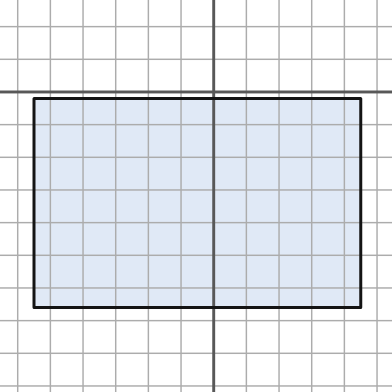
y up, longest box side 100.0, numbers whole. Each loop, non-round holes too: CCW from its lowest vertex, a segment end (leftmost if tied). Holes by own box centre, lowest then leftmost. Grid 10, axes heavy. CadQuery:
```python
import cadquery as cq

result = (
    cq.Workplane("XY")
    .moveTo(-55.0, -66.0)
    .lineTo(45.0, -66.0)
    .lineTo(45.0, -2.0)
    .lineTo(-55.0, -2.0)
    .close()
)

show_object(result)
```